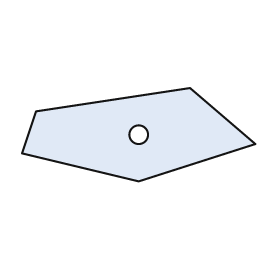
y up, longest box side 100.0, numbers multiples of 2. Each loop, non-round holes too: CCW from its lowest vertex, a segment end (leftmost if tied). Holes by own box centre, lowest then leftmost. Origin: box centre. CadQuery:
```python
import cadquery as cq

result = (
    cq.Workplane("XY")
    .moveTo(0.0, -20.0)
    .lineTo(50.0, -4.0)
    .lineTo(22.0, 20.0)
    .lineTo(-44.0, 10.0)
    .lineTo(-50.0, -8.0)
    .close()
    .moveTo(0.0, 0.0)
    .circle(4.0)
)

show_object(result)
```